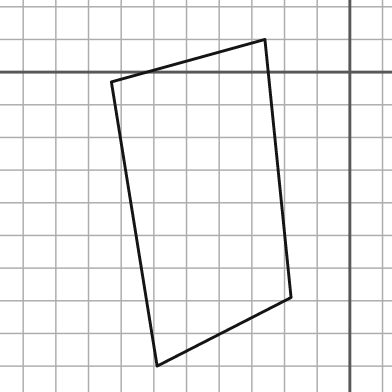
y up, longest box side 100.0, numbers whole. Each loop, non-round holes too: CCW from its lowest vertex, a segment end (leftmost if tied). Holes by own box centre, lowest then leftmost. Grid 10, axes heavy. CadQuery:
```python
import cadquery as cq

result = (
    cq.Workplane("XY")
    .moveTo(-59.0, -90.0)
    .lineTo(-18.0, -69.0)
    .lineTo(-26.0, 10.0)
    .lineTo(-73.0, -3.0)
    .close()
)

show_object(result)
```